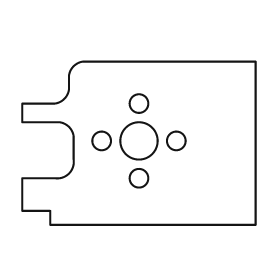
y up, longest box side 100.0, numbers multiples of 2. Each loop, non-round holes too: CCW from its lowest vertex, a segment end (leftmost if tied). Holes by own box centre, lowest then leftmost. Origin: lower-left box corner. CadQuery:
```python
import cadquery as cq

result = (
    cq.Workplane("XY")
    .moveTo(12.0, 0.0)
    .lineTo(100.0, 0.0)
    .lineTo(100.0, 70.0)
    .lineTo(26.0, 70.0)
    .threePointArc((22.0, 68.0), (20.0, 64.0))
    .lineTo(20.0, 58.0)
    .threePointArc((18.0, 54.0), (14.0, 52.0))
    .lineTo(0.0, 52.0)
    .lineTo(0.0, 44.0)
    .lineTo(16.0, 44.0)
    .threePointArc((20.0, 42.0), (22.0, 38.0))
    .lineTo(22.0, 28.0)
    .threePointArc((20.0, 22.0), (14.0, 20.0))
    .lineTo(0.0, 20.0)
    .lineTo(0.0, 6.0)
    .lineTo(12.0, 6.0)
    .close()
    .moveTo(50.0, 20.0)
    .circle(4.0)
    .moveTo(34.0, 36.0)
    .circle(4.0)
    .moveTo(50.0, 36.0)
    .circle(8.0)
    .moveTo(66.0, 36.0)
    .circle(4.0)
    .moveTo(50.0, 52.0)
    .circle(4.0)
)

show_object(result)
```